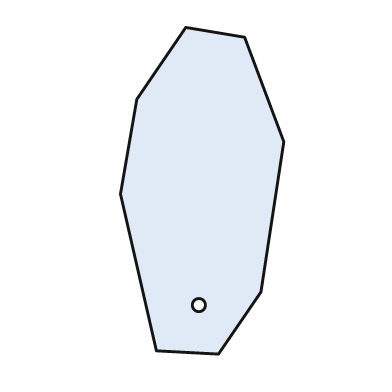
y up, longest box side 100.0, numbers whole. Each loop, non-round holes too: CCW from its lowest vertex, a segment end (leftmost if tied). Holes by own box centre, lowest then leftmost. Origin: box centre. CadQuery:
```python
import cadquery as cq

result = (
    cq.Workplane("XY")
    .moveTo(5.0, -50.0)
    .lineTo(18.0, -31.0)
    .lineTo(25.0, 15.0)
    .lineTo(13.0, 47.0)
    .lineTo(-5.0, 50.0)
    .lineTo(-20.0, 28.0)
    .lineTo(-25.0, -1.0)
    .lineTo(-14.0, -49.0)
    .close()
    .moveTo(-1.0, -35.0)
    .circle(2.0)
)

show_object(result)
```